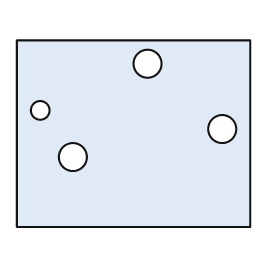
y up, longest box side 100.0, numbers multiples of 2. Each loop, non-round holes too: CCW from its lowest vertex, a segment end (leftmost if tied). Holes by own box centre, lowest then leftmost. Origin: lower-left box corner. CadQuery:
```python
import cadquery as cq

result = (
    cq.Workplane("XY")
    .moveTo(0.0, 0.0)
    .lineTo(100.0, 0.0)
    .lineTo(100.0, 80.0)
    .lineTo(0.0, 80.0)
    .close()
    .moveTo(24.0, 30.0)
    .circle(6.0)
    .moveTo(88.0, 42.0)
    .circle(6.0)
    .moveTo(10.0, 50.0)
    .circle(4.0)
    .moveTo(56.0, 70.0)
    .circle(6.0)
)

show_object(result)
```